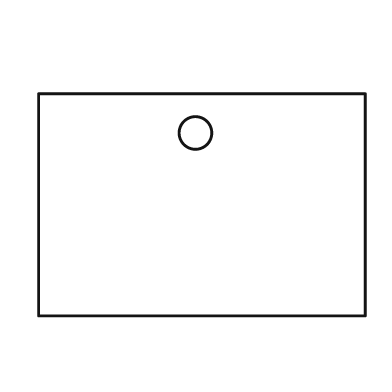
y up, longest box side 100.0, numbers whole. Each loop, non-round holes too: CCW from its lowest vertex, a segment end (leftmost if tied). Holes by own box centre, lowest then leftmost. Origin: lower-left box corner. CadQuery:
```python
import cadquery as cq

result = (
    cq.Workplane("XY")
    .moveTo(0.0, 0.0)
    .lineTo(100.0, 0.0)
    .lineTo(100.0, 68.0)
    .lineTo(0.0, 68.0)
    .close()
    .moveTo(48.0, 56.0)
    .circle(5.0)
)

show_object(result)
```